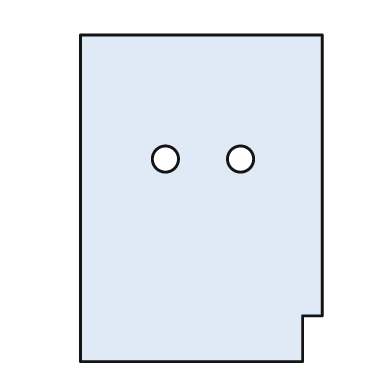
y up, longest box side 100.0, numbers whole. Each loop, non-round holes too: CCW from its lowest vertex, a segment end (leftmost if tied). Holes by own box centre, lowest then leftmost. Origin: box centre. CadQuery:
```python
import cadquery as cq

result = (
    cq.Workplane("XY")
    .moveTo(-37.0, -50.0)
    .lineTo(31.0, -50.0)
    .lineTo(31.0, -36.0)
    .lineTo(37.0, -36.0)
    .lineTo(37.0, 50.0)
    .lineTo(-37.0, 50.0)
    .close()
    .moveTo(-11.0, 12.0)
    .circle(4.0)
    .moveTo(12.0, 12.0)
    .circle(4.0)
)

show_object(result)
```